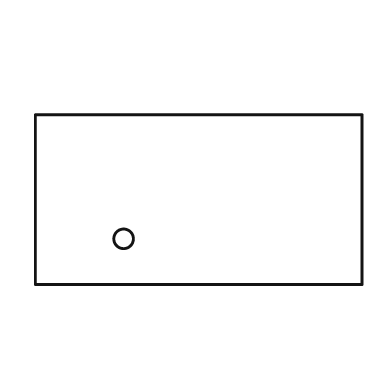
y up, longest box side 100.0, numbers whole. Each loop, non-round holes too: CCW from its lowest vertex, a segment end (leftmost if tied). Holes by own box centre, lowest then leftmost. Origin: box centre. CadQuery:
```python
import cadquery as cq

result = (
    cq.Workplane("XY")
    .moveTo(-50.0, -26.0)
    .lineTo(50.0, -26.0)
    .lineTo(50.0, 26.0)
    .lineTo(-50.0, 26.0)
    .close()
    .moveTo(-23.0, -12.0)
    .circle(3.0)
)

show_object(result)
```